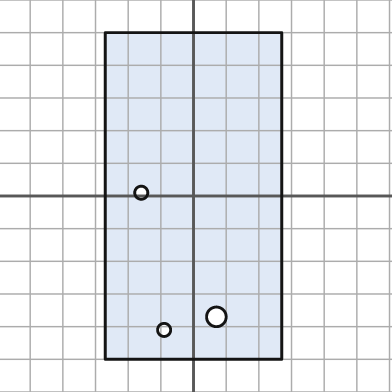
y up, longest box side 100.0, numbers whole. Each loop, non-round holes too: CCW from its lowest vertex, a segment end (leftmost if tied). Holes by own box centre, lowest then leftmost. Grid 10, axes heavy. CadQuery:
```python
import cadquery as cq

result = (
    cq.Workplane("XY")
    .moveTo(-27.0, -50.0)
    .lineTo(27.0, -50.0)
    .lineTo(27.0, 50.0)
    .lineTo(-27.0, 50.0)
    .close()
    .moveTo(-9.0, -41.0)
    .circle(2.0)
    .moveTo(7.0, -37.0)
    .circle(3.0)
    .moveTo(-16.0, 1.0)
    .circle(2.0)
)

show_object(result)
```